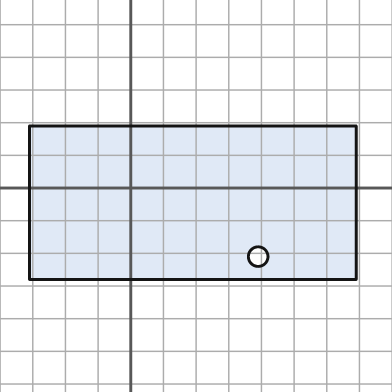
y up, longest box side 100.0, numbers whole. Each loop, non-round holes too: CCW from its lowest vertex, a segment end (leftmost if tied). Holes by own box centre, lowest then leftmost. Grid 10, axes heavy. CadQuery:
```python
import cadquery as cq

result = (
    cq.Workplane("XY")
    .moveTo(-31.0, -28.0)
    .lineTo(69.0, -28.0)
    .lineTo(69.0, 19.0)
    .lineTo(-31.0, 19.0)
    .close()
    .moveTo(39.0, -21.0)
    .circle(3.0)
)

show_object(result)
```